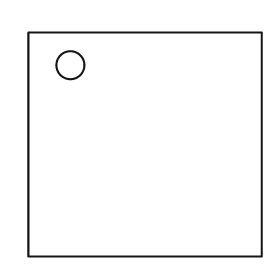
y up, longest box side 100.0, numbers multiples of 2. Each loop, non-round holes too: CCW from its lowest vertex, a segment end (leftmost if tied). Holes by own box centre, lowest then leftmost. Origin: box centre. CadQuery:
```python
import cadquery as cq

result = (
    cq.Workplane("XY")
    .moveTo(-50.0, -48.0)
    .lineTo(50.0, -48.0)
    .lineTo(50.0, 48.0)
    .lineTo(-50.0, 48.0)
    .close()
    .moveTo(-32.0, 34.0)
    .circle(6.0)
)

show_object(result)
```